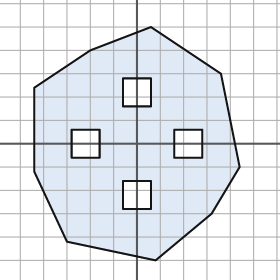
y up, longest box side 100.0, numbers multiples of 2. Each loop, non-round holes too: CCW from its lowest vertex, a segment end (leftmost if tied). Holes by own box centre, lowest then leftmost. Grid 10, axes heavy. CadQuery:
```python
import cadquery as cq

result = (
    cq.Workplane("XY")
    .moveTo(8.0, -50.0)
    .lineTo(32.0, -30.0)
    .lineTo(44.0, -10.0)
    .lineTo(36.0, 30.0)
    .lineTo(6.0, 50.0)
    .lineTo(-20.0, 40.0)
    .lineTo(-44.0, 24.0)
    .lineTo(-44.0, -12.0)
    .lineTo(-30.0, -42.0)
    .close()
    .moveTo(-6.0, -28.0)
    .lineTo(6.0, -28.0)
    .lineTo(6.0, -16.0)
    .lineTo(-6.0, -16.0)
    .close()
    .moveTo(-28.0, -6.0)
    .lineTo(-16.0, -6.0)
    .lineTo(-16.0, 6.0)
    .lineTo(-28.0, 6.0)
    .close()
    .moveTo(16.0, -6.0)
    .lineTo(28.0, -6.0)
    .lineTo(28.0, 6.0)
    .lineTo(16.0, 6.0)
    .close()
    .moveTo(-6.0, 16.0)
    .lineTo(6.0, 16.0)
    .lineTo(6.0, 28.0)
    .lineTo(-6.0, 28.0)
    .close()
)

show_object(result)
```